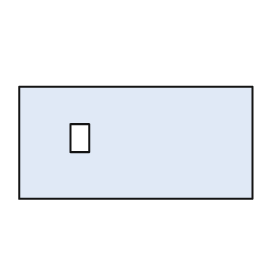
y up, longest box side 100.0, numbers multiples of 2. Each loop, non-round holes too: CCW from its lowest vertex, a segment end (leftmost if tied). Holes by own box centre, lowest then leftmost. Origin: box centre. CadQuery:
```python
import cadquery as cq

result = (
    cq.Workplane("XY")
    .moveTo(-50.0, -24.0)
    .lineTo(50.0, -24.0)
    .lineTo(50.0, 24.0)
    .lineTo(-50.0, 24.0)
    .close()
    .moveTo(-28.0, -4.0)
    .lineTo(-20.0, -4.0)
    .lineTo(-20.0, 8.0)
    .lineTo(-28.0, 8.0)
    .close()
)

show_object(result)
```